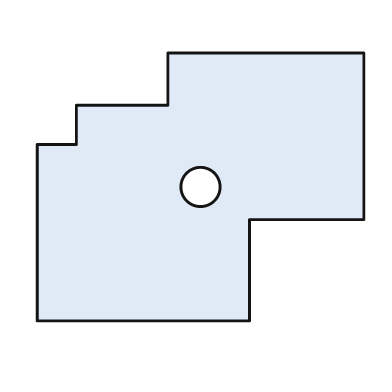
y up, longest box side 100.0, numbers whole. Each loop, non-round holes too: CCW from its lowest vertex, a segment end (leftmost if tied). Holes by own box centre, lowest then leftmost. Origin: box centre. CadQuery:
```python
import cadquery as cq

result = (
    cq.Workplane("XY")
    .moveTo(-50.0, -41.0)
    .lineTo(15.0, -41.0)
    .lineTo(15.0, -10.0)
    .lineTo(50.0, -10.0)
    .lineTo(50.0, 41.0)
    .lineTo(-10.0, 41.0)
    .lineTo(-10.0, 25.0)
    .lineTo(-38.0, 25.0)
    .lineTo(-38.0, 13.0)
    .lineTo(-50.0, 13.0)
    .close()
    .moveTo(0.0, 0.0)
    .circle(6.0)
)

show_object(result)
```